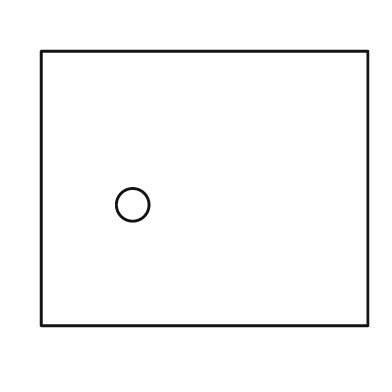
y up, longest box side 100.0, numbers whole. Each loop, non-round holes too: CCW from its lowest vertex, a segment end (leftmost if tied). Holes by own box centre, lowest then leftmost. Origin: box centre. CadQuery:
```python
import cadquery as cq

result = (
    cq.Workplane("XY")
    .moveTo(-50.0, -42.0)
    .lineTo(50.0, -42.0)
    .lineTo(50.0, 42.0)
    .lineTo(-50.0, 42.0)
    .close()
    .moveTo(-22.0, -5.0)
    .circle(5.0)
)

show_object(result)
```